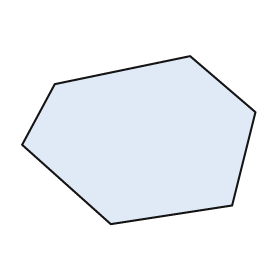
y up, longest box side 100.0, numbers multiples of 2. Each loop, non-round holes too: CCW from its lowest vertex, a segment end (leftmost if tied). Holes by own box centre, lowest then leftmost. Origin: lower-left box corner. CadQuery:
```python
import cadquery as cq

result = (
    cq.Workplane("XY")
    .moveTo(38.0, 0.0)
    .lineTo(90.0, 8.0)
    .lineTo(100.0, 48.0)
    .lineTo(72.0, 72.0)
    .lineTo(14.0, 60.0)
    .lineTo(0.0, 34.0)
    .close()
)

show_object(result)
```